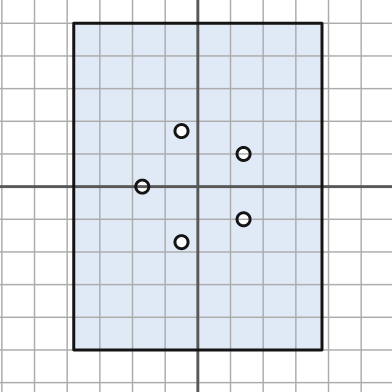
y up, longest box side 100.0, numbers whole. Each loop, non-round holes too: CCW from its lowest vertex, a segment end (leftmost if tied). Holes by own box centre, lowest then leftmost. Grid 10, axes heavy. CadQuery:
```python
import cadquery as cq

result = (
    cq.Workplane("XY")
    .moveTo(-38.0, -50.0)
    .lineTo(38.0, -50.0)
    .lineTo(38.0, 50.0)
    .lineTo(-38.0, 50.0)
    .close()
    .moveTo(-5.0, -17.0)
    .circle(2.0)
    .moveTo(14.0, -10.0)
    .circle(2.0)
    .moveTo(-17.0, 0.0)
    .circle(2.0)
    .moveTo(14.0, 10.0)
    .circle(2.0)
    .moveTo(-5.0, 17.0)
    .circle(2.0)
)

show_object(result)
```